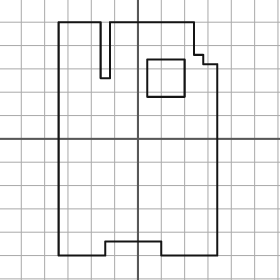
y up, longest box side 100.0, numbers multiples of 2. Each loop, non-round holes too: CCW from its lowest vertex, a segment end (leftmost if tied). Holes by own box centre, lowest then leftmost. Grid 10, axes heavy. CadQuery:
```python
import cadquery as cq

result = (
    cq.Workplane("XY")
    .moveTo(-34.0, -50.0)
    .lineTo(-14.0, -50.0)
    .lineTo(-14.0, -44.0)
    .lineTo(10.0, -44.0)
    .lineTo(10.0, -50.0)
    .lineTo(34.0, -50.0)
    .lineTo(34.0, 32.0)
    .lineTo(28.0, 32.0)
    .lineTo(28.0, 36.0)
    .lineTo(24.0, 36.0)
    .lineTo(24.0, 50.0)
    .lineTo(-12.0, 50.0)
    .lineTo(-12.0, 26.0)
    .lineTo(-16.0, 26.0)
    .lineTo(-16.0, 50.0)
    .lineTo(-34.0, 50.0)
    .close()
    .moveTo(4.0, 18.0)
    .lineTo(20.0, 18.0)
    .lineTo(20.0, 34.0)
    .lineTo(4.0, 34.0)
    .close()
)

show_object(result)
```